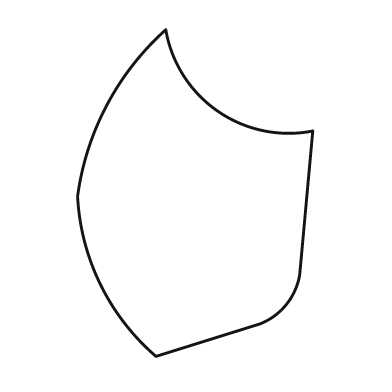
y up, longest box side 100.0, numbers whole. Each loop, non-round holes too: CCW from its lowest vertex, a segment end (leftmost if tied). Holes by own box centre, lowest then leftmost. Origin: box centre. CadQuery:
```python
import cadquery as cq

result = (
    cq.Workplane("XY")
    .moveTo(-12.0, -50.0)
    .lineTo(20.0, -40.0)
    .threePointArc((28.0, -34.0), (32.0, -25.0))
    .lineTo(36.0, 19.0)
    .threePointArc((7.0, 25.0), (-9.0, 50.0))
    .threePointArc((-27.0, 27.0), (-36.0, -1.0))
    .threePointArc((-29.0, -28.0), (-12.0, -50.0))
    .close()
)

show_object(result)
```